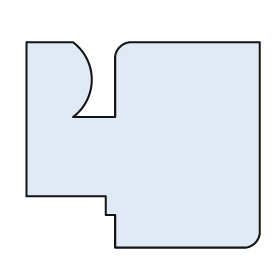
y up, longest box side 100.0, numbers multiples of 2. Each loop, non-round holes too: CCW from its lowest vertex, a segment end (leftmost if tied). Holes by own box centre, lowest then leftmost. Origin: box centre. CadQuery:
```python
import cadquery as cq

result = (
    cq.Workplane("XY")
    .moveTo(-12.0, -44.0)
    .lineTo(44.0, -44.0)
    .threePointArc((48.0, -42.0), (50.0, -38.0))
    .lineTo(50.0, 44.0)
    .lineTo(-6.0, 44.0)
    .threePointArc((-10.0, 42.0), (-12.0, 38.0))
    .lineTo(-12.0, 12.0)
    .lineTo(-30.0, 12.0)
    .threePointArc((-22.0, 28.0), (-30.0, 44.0))
    .lineTo(-50.0, 44.0)
    .lineTo(-50.0, -22.0)
    .lineTo(-16.0, -22.0)
    .lineTo(-16.0, -30.0)
    .lineTo(-12.0, -30.0)
    .close()
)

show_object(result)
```